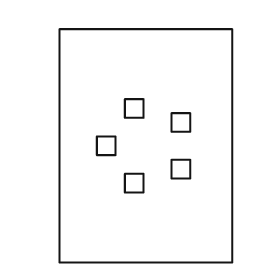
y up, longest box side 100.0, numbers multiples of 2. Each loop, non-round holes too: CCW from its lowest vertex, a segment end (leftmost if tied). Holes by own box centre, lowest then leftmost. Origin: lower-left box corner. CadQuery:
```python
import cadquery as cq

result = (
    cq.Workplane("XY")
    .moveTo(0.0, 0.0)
    .lineTo(74.0, 0.0)
    .lineTo(74.0, 100.0)
    .lineTo(0.0, 100.0)
    .close()
    .moveTo(28.0, 30.0)
    .lineTo(36.0, 30.0)
    .lineTo(36.0, 38.0)
    .lineTo(28.0, 38.0)
    .close()
    .moveTo(48.0, 36.0)
    .lineTo(56.0, 36.0)
    .lineTo(56.0, 44.0)
    .lineTo(48.0, 44.0)
    .close()
    .moveTo(16.0, 46.0)
    .lineTo(24.0, 46.0)
    .lineTo(24.0, 54.0)
    .lineTo(16.0, 54.0)
    .close()
    .moveTo(48.0, 56.0)
    .lineTo(56.0, 56.0)
    .lineTo(56.0, 64.0)
    .lineTo(48.0, 64.0)
    .close()
    .moveTo(28.0, 62.0)
    .lineTo(36.0, 62.0)
    .lineTo(36.0, 70.0)
    .lineTo(28.0, 70.0)
    .close()
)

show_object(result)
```